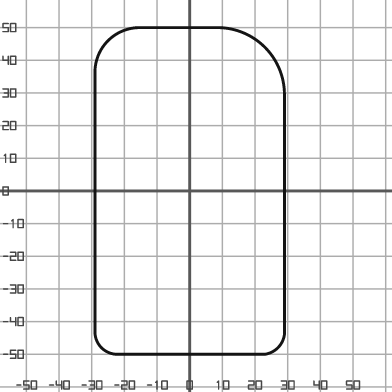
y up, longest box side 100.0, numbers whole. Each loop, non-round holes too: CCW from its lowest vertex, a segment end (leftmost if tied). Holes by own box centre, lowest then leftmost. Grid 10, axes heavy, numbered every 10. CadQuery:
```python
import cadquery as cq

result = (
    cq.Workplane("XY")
    .moveTo(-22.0, -50.0)
    .lineTo(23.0, -50.0)
    .threePointArc((27.0, -48.0), (29.0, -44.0))
    .lineTo(29.0, 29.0)
    .threePointArc((23.0, 44.0), (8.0, 50.0))
    .lineTo(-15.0, 50.0)
    .threePointArc((-25.0, 46.0), (-29.0, 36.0))
    .lineTo(-29.0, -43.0)
    .threePointArc((-27.0, -48.0), (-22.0, -50.0))
    .close()
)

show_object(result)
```